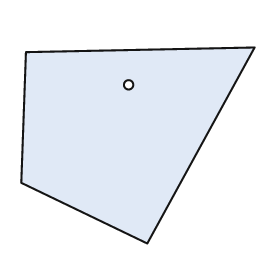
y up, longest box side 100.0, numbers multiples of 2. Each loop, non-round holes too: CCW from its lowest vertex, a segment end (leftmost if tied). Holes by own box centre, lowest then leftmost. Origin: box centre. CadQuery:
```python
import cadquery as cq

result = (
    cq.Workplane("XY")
    .moveTo(4.0, -42.0)
    .lineTo(50.0, 42.0)
    .lineTo(-48.0, 40.0)
    .lineTo(-50.0, -16.0)
    .close()
    .moveTo(-4.0, 26.0)
    .circle(2.0)
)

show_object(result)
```